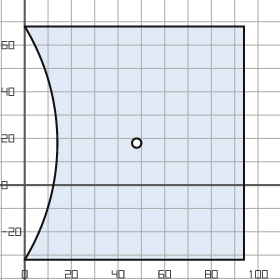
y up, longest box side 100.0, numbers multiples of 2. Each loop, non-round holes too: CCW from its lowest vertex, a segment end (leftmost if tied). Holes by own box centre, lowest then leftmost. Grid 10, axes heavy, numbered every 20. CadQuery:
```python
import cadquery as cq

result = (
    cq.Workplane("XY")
    .moveTo(0.0, -32.0)
    .lineTo(94.0, -32.0)
    .lineTo(94.0, 68.0)
    .lineTo(0.0, 68.0)
    .threePointArc((14.0, 18.0), (0.0, -32.0))
    .close()
    .moveTo(48.0, 18.0)
    .circle(2.0)
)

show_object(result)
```